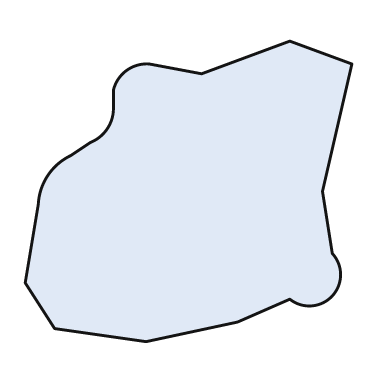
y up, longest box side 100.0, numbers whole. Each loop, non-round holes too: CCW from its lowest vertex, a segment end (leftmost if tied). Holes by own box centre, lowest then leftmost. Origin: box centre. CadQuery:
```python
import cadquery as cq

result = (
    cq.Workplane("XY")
    .moveTo(-13.0, -46.0)
    .lineTo(15.0, -40.0)
    .lineTo(31.0, -33.0)
    .threePointArc((44.0, -32.0), (44.0, -19.0))
    .lineTo(41.0, 0.0)
    .lineTo(50.0, 39.0)
    .lineTo(31.0, 46.0)
    .lineTo(4.0, 36.0)
    .lineTo(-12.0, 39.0)
    .threePointArc((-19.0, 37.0), (-23.0, 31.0))
    .lineTo(-23.0, 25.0)
    .threePointArc((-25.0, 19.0), (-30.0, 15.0))
    .lineTo(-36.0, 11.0)
    .threePointArc((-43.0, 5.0), (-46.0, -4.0))
    .lineTo(-50.0, -28.0)
    .lineTo(-41.0, -42.0)
    .close()
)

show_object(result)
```